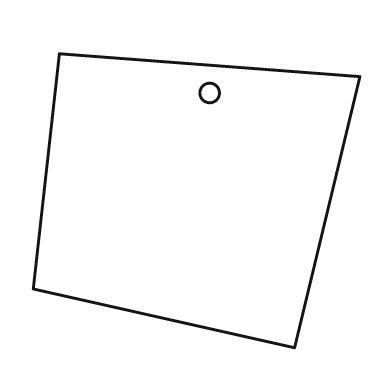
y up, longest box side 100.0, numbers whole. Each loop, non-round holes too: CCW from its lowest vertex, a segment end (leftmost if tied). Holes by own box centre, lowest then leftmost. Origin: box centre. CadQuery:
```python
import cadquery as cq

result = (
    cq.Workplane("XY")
    .moveTo(30.0, -45.0)
    .lineTo(50.0, 38.0)
    .lineTo(-42.0, 45.0)
    .lineTo(-50.0, -27.0)
    .close()
    .moveTo(4.0, 33.0)
    .circle(3.0)
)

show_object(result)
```